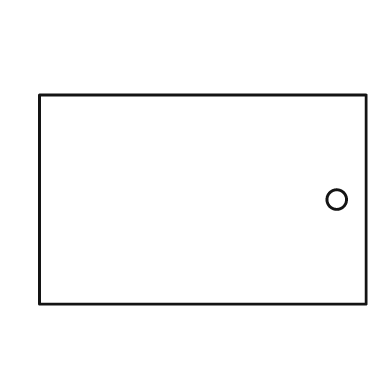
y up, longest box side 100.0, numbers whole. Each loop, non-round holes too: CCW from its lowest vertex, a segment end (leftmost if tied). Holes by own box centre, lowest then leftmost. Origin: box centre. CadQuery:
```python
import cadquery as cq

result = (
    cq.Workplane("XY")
    .moveTo(-50.0, -32.0)
    .lineTo(50.0, -32.0)
    .lineTo(50.0, 32.0)
    .lineTo(-50.0, 32.0)
    .close()
    .moveTo(41.0, 0.0)
    .circle(3.0)
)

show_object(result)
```